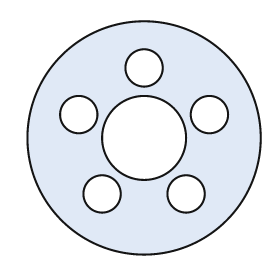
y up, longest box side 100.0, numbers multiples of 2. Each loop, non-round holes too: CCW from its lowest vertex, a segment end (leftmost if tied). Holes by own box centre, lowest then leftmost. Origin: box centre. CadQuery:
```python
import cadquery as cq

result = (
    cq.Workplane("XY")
    .moveTo(0.0, 0.0)
    .circle(50.0)
    .moveTo(-18.0, -24.0)
    .circle(8.0)
    .moveTo(18.0, -24.0)
    .circle(8.0)
    .moveTo(0.0, 0.0)
    .circle(18.0)
    .moveTo(-28.0, 10.0)
    .circle(8.0)
    .moveTo(28.0, 10.0)
    .circle(8.0)
    .moveTo(0.0, 30.0)
    .circle(8.0)
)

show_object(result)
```